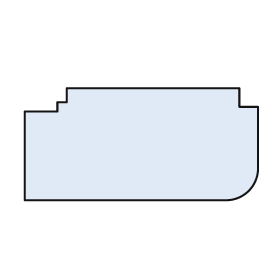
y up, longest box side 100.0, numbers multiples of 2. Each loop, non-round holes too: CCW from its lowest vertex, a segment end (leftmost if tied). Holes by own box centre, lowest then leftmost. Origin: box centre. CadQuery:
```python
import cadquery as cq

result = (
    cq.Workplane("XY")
    .moveTo(-50.0, -24.0)
    .lineTo(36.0, -24.0)
    .threePointArc((46.0, -20.0), (50.0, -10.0))
    .lineTo(50.0, 16.0)
    .lineTo(42.0, 16.0)
    .lineTo(42.0, 24.0)
    .lineTo(-32.0, 24.0)
    .lineTo(-32.0, 18.0)
    .lineTo(-36.0, 18.0)
    .lineTo(-36.0, 14.0)
    .lineTo(-50.0, 14.0)
    .close()
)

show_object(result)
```